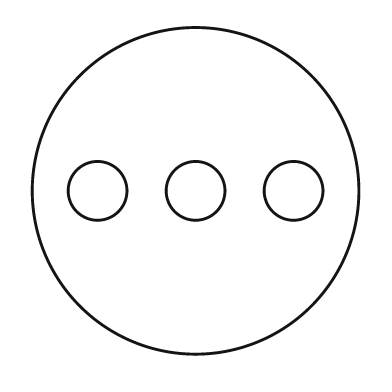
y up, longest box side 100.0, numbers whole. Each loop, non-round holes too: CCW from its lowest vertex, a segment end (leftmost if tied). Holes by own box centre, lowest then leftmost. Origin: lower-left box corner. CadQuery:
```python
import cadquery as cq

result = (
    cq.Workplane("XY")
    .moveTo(50.0, 50.0)
    .circle(50.0)
    .moveTo(20.0, 50.0)
    .circle(9.0)
    .moveTo(50.0, 50.0)
    .circle(9.0)
    .moveTo(80.0, 50.0)
    .circle(9.0)
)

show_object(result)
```